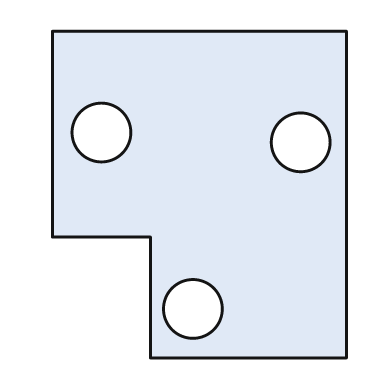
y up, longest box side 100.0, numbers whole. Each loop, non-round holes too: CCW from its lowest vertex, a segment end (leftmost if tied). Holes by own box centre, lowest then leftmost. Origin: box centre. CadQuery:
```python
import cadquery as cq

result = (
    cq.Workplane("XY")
    .moveTo(-15.0, -50.0)
    .lineTo(45.0, -50.0)
    .lineTo(45.0, 50.0)
    .lineTo(-45.0, 50.0)
    .lineTo(-45.0, -13.0)
    .lineTo(-15.0, -13.0)
    .close()
    .moveTo(-2.0, -35.0)
    .circle(9.0)
    .moveTo(31.0, 16.0)
    .circle(9.0)
    .moveTo(-30.0, 19.0)
    .circle(9.0)
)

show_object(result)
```